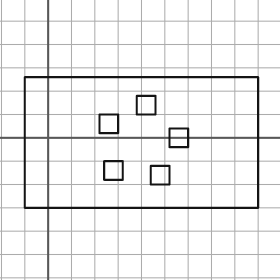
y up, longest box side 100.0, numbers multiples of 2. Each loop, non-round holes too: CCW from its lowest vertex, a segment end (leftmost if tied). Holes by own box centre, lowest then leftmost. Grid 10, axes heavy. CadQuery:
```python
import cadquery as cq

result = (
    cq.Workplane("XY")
    .moveTo(-10.0, -30.0)
    .lineTo(90.0, -30.0)
    .lineTo(90.0, 26.0)
    .lineTo(-10.0, 26.0)
    .close()
    .moveTo(44.0, -20.0)
    .lineTo(52.0, -20.0)
    .lineTo(52.0, -12.0)
    .lineTo(44.0, -12.0)
    .close()
    .moveTo(24.0, -18.0)
    .lineTo(32.0, -18.0)
    .lineTo(32.0, -10.0)
    .lineTo(24.0, -10.0)
    .close()
    .moveTo(52.0, -4.0)
    .lineTo(60.0, -4.0)
    .lineTo(60.0, 4.0)
    .lineTo(52.0, 4.0)
    .close()
    .moveTo(22.0, 2.0)
    .lineTo(30.0, 2.0)
    .lineTo(30.0, 10.0)
    .lineTo(22.0, 10.0)
    .close()
    .moveTo(38.0, 10.0)
    .lineTo(46.0, 10.0)
    .lineTo(46.0, 18.0)
    .lineTo(38.0, 18.0)
    .close()
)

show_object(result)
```